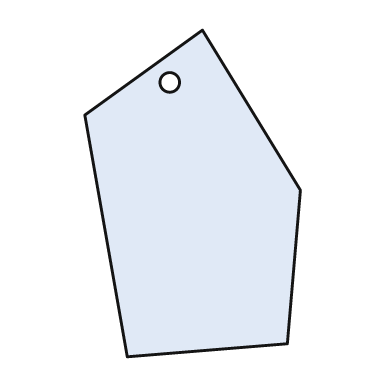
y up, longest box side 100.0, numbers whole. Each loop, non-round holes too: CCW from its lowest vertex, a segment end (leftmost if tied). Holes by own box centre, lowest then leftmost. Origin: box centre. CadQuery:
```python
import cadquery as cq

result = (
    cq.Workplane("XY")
    .moveTo(-20.0, -50.0)
    .lineTo(29.0, -46.0)
    .lineTo(33.0, 1.0)
    .lineTo(3.0, 50.0)
    .lineTo(-33.0, 24.0)
    .close()
    .moveTo(-7.0, 34.0)
    .circle(3.0)
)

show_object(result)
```